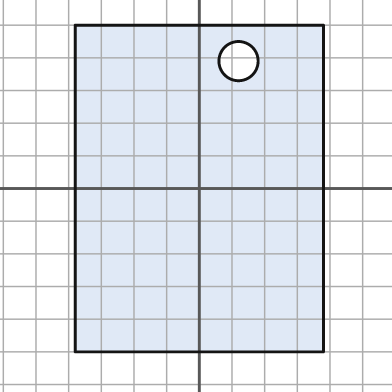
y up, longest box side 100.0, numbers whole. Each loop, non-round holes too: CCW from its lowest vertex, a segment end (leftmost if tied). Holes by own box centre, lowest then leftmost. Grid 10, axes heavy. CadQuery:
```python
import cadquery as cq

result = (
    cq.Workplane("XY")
    .moveTo(-38.0, -50.0)
    .lineTo(38.0, -50.0)
    .lineTo(38.0, 50.0)
    .lineTo(-38.0, 50.0)
    .close()
    .moveTo(12.0, 39.0)
    .circle(6.0)
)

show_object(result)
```